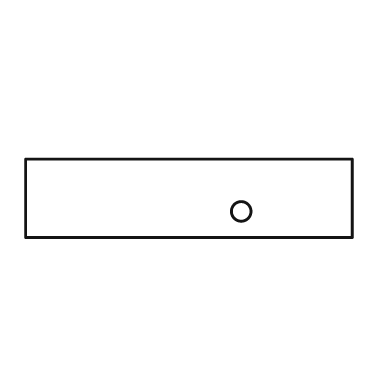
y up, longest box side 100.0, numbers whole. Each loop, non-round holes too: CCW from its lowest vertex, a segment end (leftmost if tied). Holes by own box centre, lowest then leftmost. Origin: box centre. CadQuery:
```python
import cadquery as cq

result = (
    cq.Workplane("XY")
    .moveTo(-50.0, -12.0)
    .lineTo(50.0, -12.0)
    .lineTo(50.0, 12.0)
    .lineTo(-50.0, 12.0)
    .close()
    .moveTo(16.0, -4.0)
    .circle(3.0)
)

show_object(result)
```